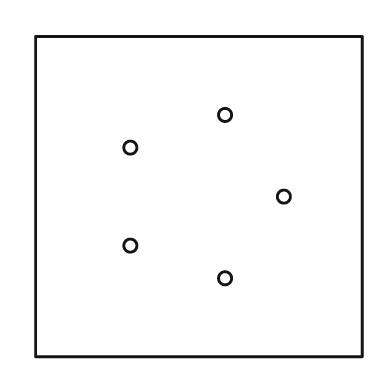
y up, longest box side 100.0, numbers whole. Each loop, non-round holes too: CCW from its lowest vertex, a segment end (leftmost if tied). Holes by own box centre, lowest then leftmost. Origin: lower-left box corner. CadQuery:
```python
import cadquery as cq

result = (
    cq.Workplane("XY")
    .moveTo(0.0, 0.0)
    .lineTo(100.0, 0.0)
    .lineTo(100.0, 98.0)
    .lineTo(0.0, 98.0)
    .close()
    .moveTo(58.0, 24.0)
    .circle(2.0)
    .moveTo(29.0, 34.0)
    .circle(2.0)
    .moveTo(76.0, 49.0)
    .circle(2.0)
    .moveTo(29.0, 64.0)
    .circle(2.0)
    .moveTo(58.0, 74.0)
    .circle(2.0)
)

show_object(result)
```